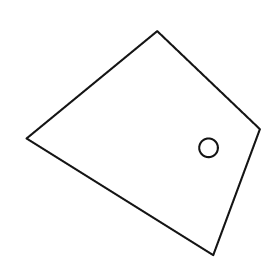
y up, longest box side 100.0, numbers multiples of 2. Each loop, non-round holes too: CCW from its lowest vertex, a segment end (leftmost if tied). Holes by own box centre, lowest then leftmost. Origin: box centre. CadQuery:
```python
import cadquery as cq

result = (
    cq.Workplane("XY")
    .moveTo(30.0, -48.0)
    .lineTo(50.0, 6.0)
    .lineTo(6.0, 48.0)
    .lineTo(-50.0, 2.0)
    .close()
    .moveTo(28.0, -2.0)
    .circle(4.0)
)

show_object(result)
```